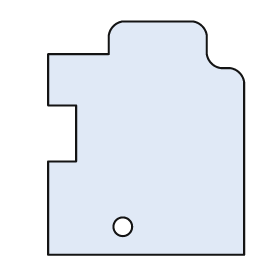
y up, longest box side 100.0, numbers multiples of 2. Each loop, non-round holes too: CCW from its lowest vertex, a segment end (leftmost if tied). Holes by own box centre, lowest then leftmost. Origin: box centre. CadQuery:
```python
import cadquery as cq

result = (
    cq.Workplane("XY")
    .moveTo(-42.0, -50.0)
    .lineTo(42.0, -50.0)
    .lineTo(42.0, 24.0)
    .threePointArc((40.0, 28.0), (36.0, 30.0))
    .lineTo(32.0, 30.0)
    .threePointArc((28.0, 32.0), (26.0, 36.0))
    .lineTo(26.0, 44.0)
    .threePointArc((24.0, 48.0), (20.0, 50.0))
    .lineTo(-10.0, 50.0)
    .threePointArc((-14.0, 48.0), (-16.0, 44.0))
    .lineTo(-16.0, 36.0)
    .lineTo(-42.0, 36.0)
    .lineTo(-42.0, 14.0)
    .lineTo(-30.0, 14.0)
    .lineTo(-30.0, -10.0)
    .lineTo(-42.0, -10.0)
    .close()
    .moveTo(-10.0, -38.0)
    .circle(4.0)
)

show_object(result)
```